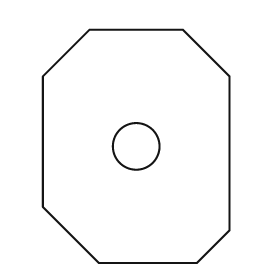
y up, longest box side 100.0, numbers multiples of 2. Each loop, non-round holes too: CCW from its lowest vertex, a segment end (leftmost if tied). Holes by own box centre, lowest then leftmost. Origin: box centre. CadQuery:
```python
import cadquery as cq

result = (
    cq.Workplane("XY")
    .moveTo(-16.0, -50.0)
    .lineTo(26.0, -50.0)
    .lineTo(40.0, -36.0)
    .lineTo(40.0, 30.0)
    .lineTo(20.0, 50.0)
    .lineTo(-20.0, 50.0)
    .lineTo(-40.0, 30.0)
    .lineTo(-40.0, -26.0)
    .close()
    .moveTo(0.0, 0.0)
    .circle(10.0)
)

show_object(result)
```